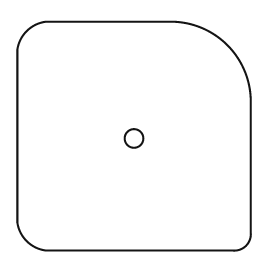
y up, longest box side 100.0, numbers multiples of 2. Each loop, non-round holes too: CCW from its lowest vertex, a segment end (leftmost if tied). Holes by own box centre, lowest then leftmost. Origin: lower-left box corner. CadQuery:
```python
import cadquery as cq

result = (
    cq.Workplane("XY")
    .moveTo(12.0, 0.0)
    .lineTo(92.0, 0.0)
    .threePointArc((98.0, 2.0), (100.0, 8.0))
    .lineTo(100.0, 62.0)
    .threePointArc((90.0, 88.0), (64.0, 98.0))
    .lineTo(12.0, 98.0)
    .threePointArc((4.0, 94.0), (0.0, 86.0))
    .lineTo(0.0, 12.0)
    .threePointArc((4.0, 4.0), (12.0, 0.0))
    .close()
    .moveTo(50.0, 48.0)
    .circle(4.0)
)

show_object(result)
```